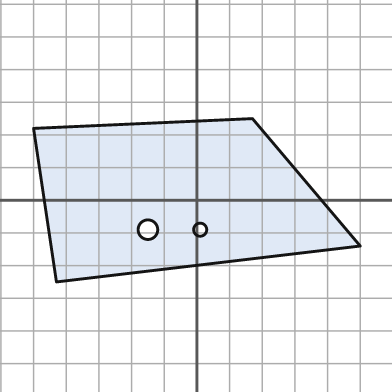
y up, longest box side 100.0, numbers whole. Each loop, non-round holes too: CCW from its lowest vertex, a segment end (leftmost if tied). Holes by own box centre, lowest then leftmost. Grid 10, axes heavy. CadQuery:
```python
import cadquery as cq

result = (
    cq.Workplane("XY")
    .moveTo(-43.0, -25.0)
    .lineTo(50.0, -14.0)
    .lineTo(17.0, 25.0)
    .lineTo(-50.0, 22.0)
    .close()
    .moveTo(-15.0, -9.0)
    .circle(3.0)
    .moveTo(1.0, -9.0)
    .circle(2.0)
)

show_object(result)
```